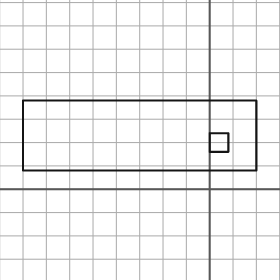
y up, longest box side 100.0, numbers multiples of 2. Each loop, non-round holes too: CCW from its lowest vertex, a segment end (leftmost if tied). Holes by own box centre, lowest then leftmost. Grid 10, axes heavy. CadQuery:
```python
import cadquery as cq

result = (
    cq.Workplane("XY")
    .moveTo(-80.0, 8.0)
    .lineTo(20.0, 8.0)
    .lineTo(20.0, 38.0)
    .lineTo(-80.0, 38.0)
    .close()
    .moveTo(0.0, 16.0)
    .lineTo(8.0, 16.0)
    .lineTo(8.0, 24.0)
    .lineTo(0.0, 24.0)
    .close()
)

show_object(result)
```